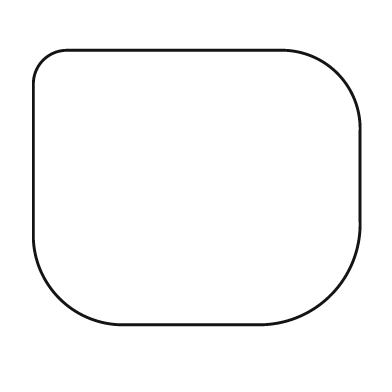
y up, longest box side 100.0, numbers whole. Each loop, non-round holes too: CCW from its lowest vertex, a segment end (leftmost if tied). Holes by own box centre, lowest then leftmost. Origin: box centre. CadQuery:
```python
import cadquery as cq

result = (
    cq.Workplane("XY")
    .moveTo(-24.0, -42.0)
    .lineTo(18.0, -42.0)
    .threePointArc((41.0, -33.0), (50.0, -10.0))
    .lineTo(50.0, 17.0)
    .threePointArc((43.0, 35.0), (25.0, 42.0))
    .lineTo(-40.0, 42.0)
    .threePointArc((-47.0, 39.0), (-50.0, 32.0))
    .lineTo(-50.0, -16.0)
    .threePointArc((-42.0, -34.0), (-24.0, -42.0))
    .close()
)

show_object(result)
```